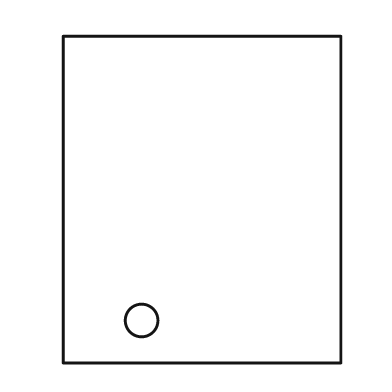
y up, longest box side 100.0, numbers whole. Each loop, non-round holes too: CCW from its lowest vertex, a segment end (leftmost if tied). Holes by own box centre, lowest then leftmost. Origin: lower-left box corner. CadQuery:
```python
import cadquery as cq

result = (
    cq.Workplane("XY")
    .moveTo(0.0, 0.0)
    .lineTo(85.0, 0.0)
    .lineTo(85.0, 100.0)
    .lineTo(0.0, 100.0)
    .close()
    .moveTo(24.0, 13.0)
    .circle(5.0)
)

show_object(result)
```